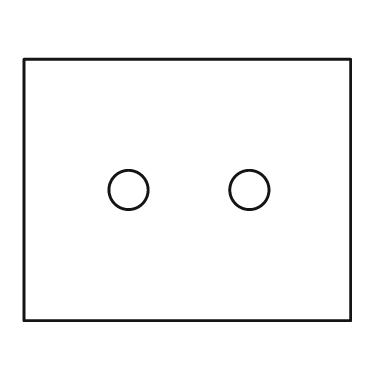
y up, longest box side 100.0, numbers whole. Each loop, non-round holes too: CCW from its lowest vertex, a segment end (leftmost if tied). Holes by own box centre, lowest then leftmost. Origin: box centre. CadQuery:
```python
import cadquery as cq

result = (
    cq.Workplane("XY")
    .moveTo(-50.0, -40.0)
    .lineTo(50.0, -40.0)
    .lineTo(50.0, 40.0)
    .lineTo(-50.0, 40.0)
    .close()
    .moveTo(-18.0, 0.0)
    .circle(6.0)
    .moveTo(19.0, 0.0)
    .circle(6.0)
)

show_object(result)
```